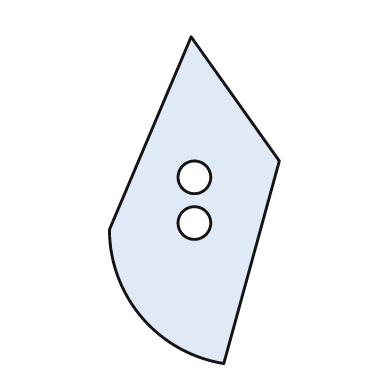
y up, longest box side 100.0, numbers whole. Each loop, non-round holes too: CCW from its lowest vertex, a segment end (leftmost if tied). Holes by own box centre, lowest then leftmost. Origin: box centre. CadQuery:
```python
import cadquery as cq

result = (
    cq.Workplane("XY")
    .moveTo(9.0, -50.0)
    .lineTo(26.0, 12.0)
    .lineTo(-1.0, 50.0)
    .lineTo(-26.0, -9.0)
    .threePointArc((-16.0, -36.0), (9.0, -50.0))
    .close()
    .moveTo(0.0, -7.0)
    .circle(5.0)
    .moveTo(0.0, 7.0)
    .circle(5.0)
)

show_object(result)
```